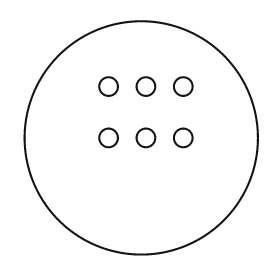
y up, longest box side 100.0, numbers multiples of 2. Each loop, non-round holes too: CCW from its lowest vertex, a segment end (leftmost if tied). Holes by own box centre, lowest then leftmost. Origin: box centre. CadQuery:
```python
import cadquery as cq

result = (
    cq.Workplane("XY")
    .moveTo(0.0, 0.0)
    .circle(50.0)
    .moveTo(-14.0, 0.0)
    .circle(4.0)
    .moveTo(2.0, 0.0)
    .circle(4.0)
    .moveTo(18.0, 0.0)
    .circle(4.0)
    .moveTo(-14.0, 22.0)
    .circle(4.0)
    .moveTo(2.0, 22.0)
    .circle(4.0)
    .moveTo(18.0, 22.0)
    .circle(4.0)
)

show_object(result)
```